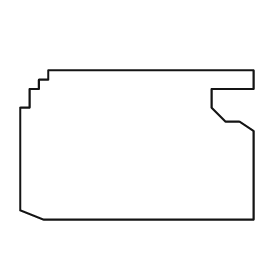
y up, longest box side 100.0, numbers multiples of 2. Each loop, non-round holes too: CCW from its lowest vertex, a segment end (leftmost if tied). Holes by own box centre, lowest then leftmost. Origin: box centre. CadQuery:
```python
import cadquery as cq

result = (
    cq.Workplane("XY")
    .moveTo(-40.0, -32.0)
    .lineTo(50.0, -32.0)
    .lineTo(50.0, 6.0)
    .lineTo(44.0, 10.0)
    .lineTo(38.0, 10.0)
    .lineTo(32.0, 16.0)
    .lineTo(32.0, 24.0)
    .lineTo(50.0, 24.0)
    .lineTo(50.0, 32.0)
    .lineTo(-38.0, 32.0)
    .lineTo(-38.0, 28.0)
    .lineTo(-42.0, 28.0)
    .lineTo(-42.0, 24.0)
    .lineTo(-46.0, 24.0)
    .lineTo(-46.0, 16.0)
    .lineTo(-50.0, 16.0)
    .lineTo(-50.0, -28.0)
    .close()
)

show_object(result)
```